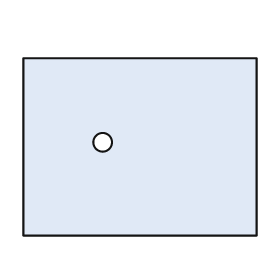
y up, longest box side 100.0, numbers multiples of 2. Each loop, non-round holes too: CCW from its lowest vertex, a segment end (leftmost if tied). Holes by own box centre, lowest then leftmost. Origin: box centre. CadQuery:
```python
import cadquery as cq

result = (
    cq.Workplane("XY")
    .moveTo(-50.0, -38.0)
    .lineTo(50.0, -38.0)
    .lineTo(50.0, 38.0)
    .lineTo(-50.0, 38.0)
    .close()
    .moveTo(-16.0, 2.0)
    .circle(4.0)
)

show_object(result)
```